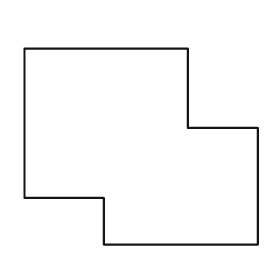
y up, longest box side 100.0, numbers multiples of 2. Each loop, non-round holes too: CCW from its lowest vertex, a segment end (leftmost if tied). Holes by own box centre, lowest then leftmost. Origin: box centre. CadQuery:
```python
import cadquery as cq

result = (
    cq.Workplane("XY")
    .moveTo(-16.0, -42.0)
    .lineTo(50.0, -42.0)
    .lineTo(50.0, 8.0)
    .lineTo(20.0, 8.0)
    .lineTo(20.0, 42.0)
    .lineTo(-50.0, 42.0)
    .lineTo(-50.0, -22.0)
    .lineTo(-16.0, -22.0)
    .close()
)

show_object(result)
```